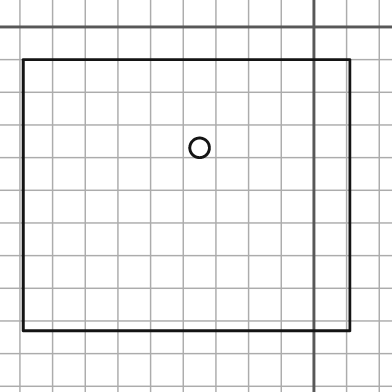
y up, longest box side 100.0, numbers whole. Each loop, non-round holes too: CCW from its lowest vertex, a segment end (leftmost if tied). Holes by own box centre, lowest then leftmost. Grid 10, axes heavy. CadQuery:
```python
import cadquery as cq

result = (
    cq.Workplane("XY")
    .moveTo(-89.0, -93.0)
    .lineTo(11.0, -93.0)
    .lineTo(11.0, -10.0)
    .lineTo(-89.0, -10.0)
    .close()
    .moveTo(-35.0, -37.0)
    .circle(3.0)
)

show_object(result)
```